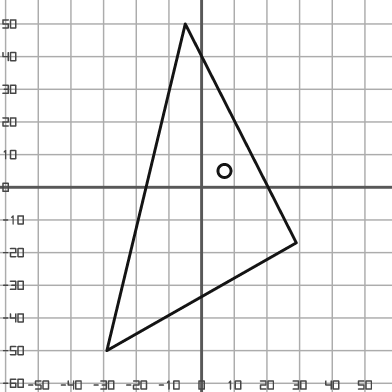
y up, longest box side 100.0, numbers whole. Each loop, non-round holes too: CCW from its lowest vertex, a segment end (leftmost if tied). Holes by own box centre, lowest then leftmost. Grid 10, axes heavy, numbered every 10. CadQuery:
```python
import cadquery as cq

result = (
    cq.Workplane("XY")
    .moveTo(-29.0, -50.0)
    .lineTo(29.0, -17.0)
    .lineTo(-5.0, 50.0)
    .close()
    .moveTo(7.0, 5.0)
    .circle(2.0)
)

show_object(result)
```